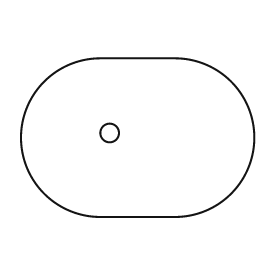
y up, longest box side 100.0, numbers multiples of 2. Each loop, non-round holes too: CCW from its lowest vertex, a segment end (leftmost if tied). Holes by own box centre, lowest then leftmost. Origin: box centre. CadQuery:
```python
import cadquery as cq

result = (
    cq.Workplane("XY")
    .moveTo(-16.0, -34.0)
    .lineTo(16.0, -34.0)
    .threePointArc((50.0, 0.0), (16.0, 34.0))
    .lineTo(-16.0, 34.0)
    .threePointArc((-50.0, 0.0), (-16.0, -34.0))
    .close()
    .moveTo(-12.0, 2.0)
    .circle(4.0)
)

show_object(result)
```